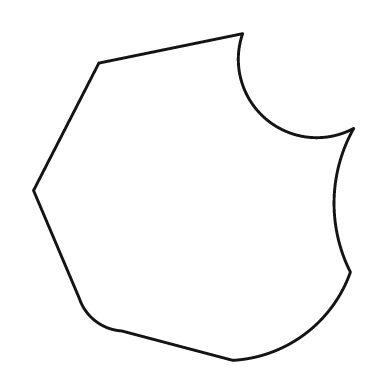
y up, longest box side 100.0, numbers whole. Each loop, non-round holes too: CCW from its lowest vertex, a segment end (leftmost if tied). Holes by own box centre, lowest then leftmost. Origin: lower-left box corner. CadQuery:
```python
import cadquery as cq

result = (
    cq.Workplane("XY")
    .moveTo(61.0, 0.0)
    .threePointArc((83.0, 8.0), (97.0, 27.0))
    .threePointArc((92.0, 49.0), (98.0, 71.0))
    .threePointArc((71.0, 74.0), (64.0, 100.0))
    .lineTo(20.0, 91.0)
    .lineTo(0.0, 52.0)
    .lineTo(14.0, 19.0)
    .threePointArc((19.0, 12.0), (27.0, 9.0))
    .close()
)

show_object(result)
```